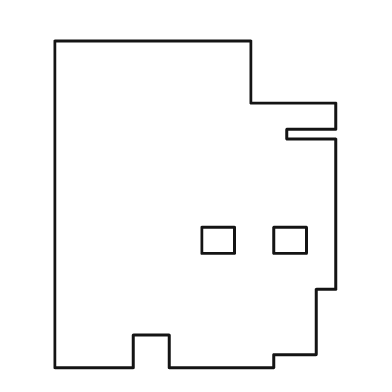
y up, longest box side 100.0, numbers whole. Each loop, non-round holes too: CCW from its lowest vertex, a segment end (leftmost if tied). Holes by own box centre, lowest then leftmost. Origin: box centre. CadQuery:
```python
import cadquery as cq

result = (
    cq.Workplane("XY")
    .moveTo(-43.0, -50.0)
    .lineTo(-19.0, -50.0)
    .lineTo(-19.0, -40.0)
    .lineTo(-8.0, -40.0)
    .lineTo(-8.0, -50.0)
    .lineTo(24.0, -50.0)
    .lineTo(24.0, -46.0)
    .lineTo(37.0, -46.0)
    .lineTo(37.0, -26.0)
    .lineTo(43.0, -26.0)
    .lineTo(43.0, 20.0)
    .lineTo(28.0, 20.0)
    .lineTo(28.0, 23.0)
    .lineTo(43.0, 23.0)
    .lineTo(43.0, 31.0)
    .lineTo(17.0, 31.0)
    .lineTo(17.0, 50.0)
    .lineTo(-43.0, 50.0)
    .close()
    .moveTo(2.0, -15.0)
    .lineTo(12.0, -15.0)
    .lineTo(12.0, -7.0)
    .lineTo(2.0, -7.0)
    .close()
    .moveTo(24.0, -15.0)
    .lineTo(34.0, -15.0)
    .lineTo(34.0, -7.0)
    .lineTo(24.0, -7.0)
    .close()
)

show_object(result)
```